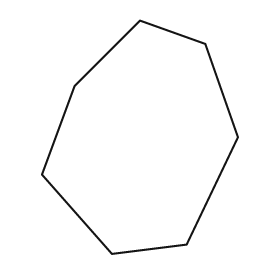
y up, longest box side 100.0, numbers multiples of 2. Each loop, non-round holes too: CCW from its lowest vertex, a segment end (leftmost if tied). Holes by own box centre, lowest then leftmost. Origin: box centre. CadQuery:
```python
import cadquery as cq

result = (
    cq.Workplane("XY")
    .moveTo(-12.0, -50.0)
    .lineTo(20.0, -46.0)
    .lineTo(42.0, 0.0)
    .lineTo(28.0, 40.0)
    .lineTo(0.0, 50.0)
    .lineTo(-28.0, 22.0)
    .lineTo(-42.0, -16.0)
    .close()
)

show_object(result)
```